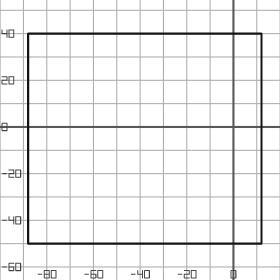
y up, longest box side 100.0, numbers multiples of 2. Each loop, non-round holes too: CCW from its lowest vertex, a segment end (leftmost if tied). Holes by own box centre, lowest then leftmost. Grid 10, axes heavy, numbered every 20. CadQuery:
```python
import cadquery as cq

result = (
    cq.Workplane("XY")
    .moveTo(-88.0, -50.0)
    .lineTo(12.0, -50.0)
    .lineTo(12.0, 40.0)
    .lineTo(-88.0, 40.0)
    .close()
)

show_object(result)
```